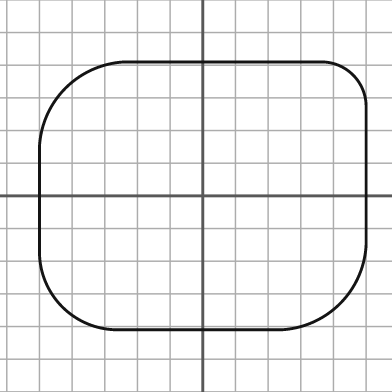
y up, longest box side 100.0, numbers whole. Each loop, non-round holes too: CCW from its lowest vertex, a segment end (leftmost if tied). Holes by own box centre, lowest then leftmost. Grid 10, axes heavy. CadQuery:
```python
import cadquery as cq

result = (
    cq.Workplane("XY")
    .moveTo(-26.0, -41.0)
    .lineTo(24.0, -41.0)
    .threePointArc((42.0, -33.0), (50.0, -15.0))
    .lineTo(50.0, 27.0)
    .threePointArc((46.0, 37.0), (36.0, 41.0))
    .lineTo(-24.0, 41.0)
    .threePointArc((-42.0, 33.0), (-50.0, 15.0))
    .lineTo(-50.0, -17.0)
    .threePointArc((-43.0, -34.0), (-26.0, -41.0))
    .close()
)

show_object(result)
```